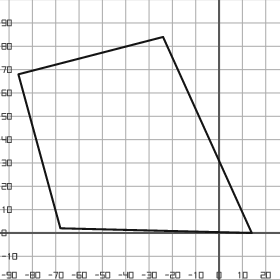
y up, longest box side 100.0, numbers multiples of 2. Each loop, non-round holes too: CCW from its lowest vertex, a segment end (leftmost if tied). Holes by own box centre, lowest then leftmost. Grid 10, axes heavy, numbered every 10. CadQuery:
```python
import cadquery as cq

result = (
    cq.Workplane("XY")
    .moveTo(14.0, 0.0)
    .lineTo(-24.0, 84.0)
    .lineTo(-86.0, 68.0)
    .lineTo(-68.0, 2.0)
    .close()
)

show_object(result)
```